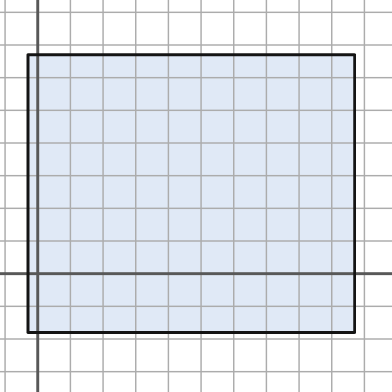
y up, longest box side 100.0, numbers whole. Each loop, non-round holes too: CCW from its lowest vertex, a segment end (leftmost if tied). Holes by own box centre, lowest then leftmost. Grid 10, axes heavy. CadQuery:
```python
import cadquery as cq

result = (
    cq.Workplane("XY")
    .moveTo(-3.0, -18.0)
    .lineTo(97.0, -18.0)
    .lineTo(97.0, 67.0)
    .lineTo(-3.0, 67.0)
    .close()
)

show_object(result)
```